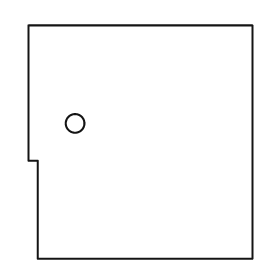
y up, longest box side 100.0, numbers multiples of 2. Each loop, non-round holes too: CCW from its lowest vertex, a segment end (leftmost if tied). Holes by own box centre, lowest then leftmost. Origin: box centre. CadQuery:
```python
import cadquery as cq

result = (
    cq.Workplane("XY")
    .moveTo(-44.0, -50.0)
    .lineTo(48.0, -50.0)
    .lineTo(48.0, 50.0)
    .lineTo(-48.0, 50.0)
    .lineTo(-48.0, -8.0)
    .lineTo(-44.0, -8.0)
    .close()
    .moveTo(-28.0, 8.0)
    .circle(4.0)
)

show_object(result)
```